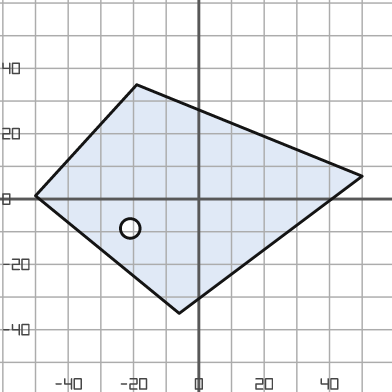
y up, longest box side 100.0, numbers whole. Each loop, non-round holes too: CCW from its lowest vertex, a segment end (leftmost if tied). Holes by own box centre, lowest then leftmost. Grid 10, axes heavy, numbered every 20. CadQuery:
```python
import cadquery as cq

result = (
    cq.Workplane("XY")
    .moveTo(-6.0, -35.0)
    .lineTo(50.0, 7.0)
    .lineTo(-19.0, 35.0)
    .lineTo(-50.0, 1.0)
    .close()
    .moveTo(-21.0, -9.0)
    .circle(3.0)
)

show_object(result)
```